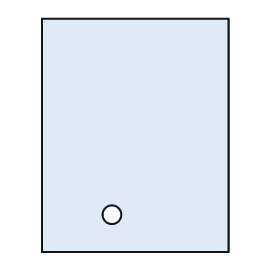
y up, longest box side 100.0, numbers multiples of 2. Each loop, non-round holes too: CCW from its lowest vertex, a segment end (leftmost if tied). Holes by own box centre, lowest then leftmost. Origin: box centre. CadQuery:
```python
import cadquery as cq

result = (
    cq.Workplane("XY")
    .moveTo(-40.0, -50.0)
    .lineTo(40.0, -50.0)
    .lineTo(40.0, 50.0)
    .lineTo(-40.0, 50.0)
    .close()
    .moveTo(-10.0, -34.0)
    .circle(4.0)
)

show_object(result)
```